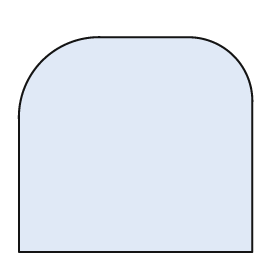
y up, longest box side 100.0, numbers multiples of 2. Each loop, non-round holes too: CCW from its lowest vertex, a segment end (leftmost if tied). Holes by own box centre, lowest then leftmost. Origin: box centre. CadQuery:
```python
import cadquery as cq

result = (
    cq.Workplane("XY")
    .moveTo(-50.0, -46.0)
    .lineTo(50.0, -46.0)
    .lineTo(50.0, 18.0)
    .threePointArc((42.0, 38.0), (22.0, 46.0))
    .lineTo(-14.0, 46.0)
    .threePointArc((-40.0, 36.0), (-50.0, 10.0))
    .close()
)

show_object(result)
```